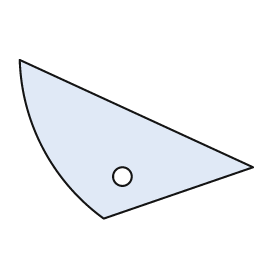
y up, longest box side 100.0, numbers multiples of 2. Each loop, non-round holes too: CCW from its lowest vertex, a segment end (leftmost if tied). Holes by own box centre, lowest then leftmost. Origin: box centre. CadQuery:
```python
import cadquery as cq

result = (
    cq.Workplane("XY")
    .moveTo(-14.0, -34.0)
    .lineTo(50.0, -12.0)
    .lineTo(-50.0, 34.0)
    .threePointArc((-40.0, -4.0), (-14.0, -34.0))
    .close()
    .moveTo(-6.0, -16.0)
    .circle(4.0)
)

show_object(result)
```